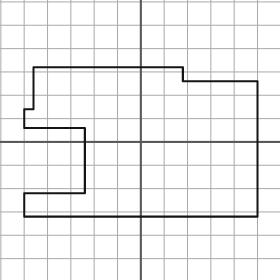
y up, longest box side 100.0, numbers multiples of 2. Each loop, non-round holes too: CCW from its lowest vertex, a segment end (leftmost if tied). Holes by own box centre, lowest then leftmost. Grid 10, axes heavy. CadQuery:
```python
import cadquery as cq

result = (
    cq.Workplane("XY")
    .moveTo(-50.0, -32.0)
    .lineTo(50.0, -32.0)
    .lineTo(50.0, 26.0)
    .lineTo(18.0, 26.0)
    .lineTo(18.0, 32.0)
    .lineTo(-46.0, 32.0)
    .lineTo(-46.0, 14.0)
    .lineTo(-50.0, 14.0)
    .lineTo(-50.0, 6.0)
    .lineTo(-24.0, 6.0)
    .lineTo(-24.0, -22.0)
    .lineTo(-50.0, -22.0)
    .close()
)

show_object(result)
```